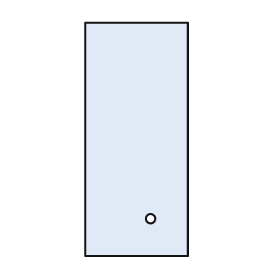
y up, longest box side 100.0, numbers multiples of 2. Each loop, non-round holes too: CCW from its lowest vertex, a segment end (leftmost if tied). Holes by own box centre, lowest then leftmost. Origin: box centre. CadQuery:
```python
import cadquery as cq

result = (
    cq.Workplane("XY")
    .moveTo(-22.0, -50.0)
    .lineTo(22.0, -50.0)
    .lineTo(22.0, 50.0)
    .lineTo(-22.0, 50.0)
    .close()
    .moveTo(6.0, -34.0)
    .circle(2.0)
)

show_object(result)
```